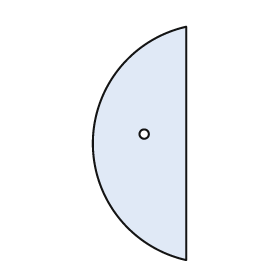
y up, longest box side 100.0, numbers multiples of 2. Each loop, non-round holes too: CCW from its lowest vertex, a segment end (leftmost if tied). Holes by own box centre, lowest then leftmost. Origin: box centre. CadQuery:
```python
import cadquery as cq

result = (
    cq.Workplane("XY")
    .moveTo(20.0, -50.0)
    .lineTo(20.0, 50.0)
    .threePointArc((-20.0, 0.0), (20.0, -50.0))
    .close()
    .moveTo(2.0, 4.0)
    .circle(2.0)
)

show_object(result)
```